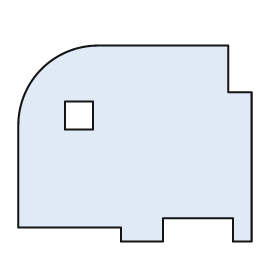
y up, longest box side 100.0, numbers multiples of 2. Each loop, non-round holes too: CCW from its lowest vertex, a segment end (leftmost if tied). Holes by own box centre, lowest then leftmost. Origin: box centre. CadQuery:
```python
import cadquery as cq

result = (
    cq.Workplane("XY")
    .moveTo(-6.0, -42.0)
    .lineTo(12.0, -42.0)
    .lineTo(12.0, -32.0)
    .lineTo(42.0, -32.0)
    .lineTo(42.0, -42.0)
    .lineTo(50.0, -42.0)
    .lineTo(50.0, 22.0)
    .lineTo(40.0, 22.0)
    .lineTo(40.0, 42.0)
    .lineTo(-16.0, 42.0)
    .threePointArc((-40.0, 32.0), (-50.0, 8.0))
    .lineTo(-50.0, -36.0)
    .lineTo(-6.0, -36.0)
    .close()
    .moveTo(-30.0, 6.0)
    .lineTo(-18.0, 6.0)
    .lineTo(-18.0, 18.0)
    .lineTo(-30.0, 18.0)
    .close()
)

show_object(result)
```